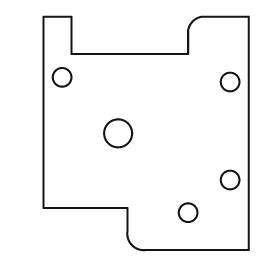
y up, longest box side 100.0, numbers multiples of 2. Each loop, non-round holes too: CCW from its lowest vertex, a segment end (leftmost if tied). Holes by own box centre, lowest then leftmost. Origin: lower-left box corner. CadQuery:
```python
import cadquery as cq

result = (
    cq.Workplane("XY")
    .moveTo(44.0, 0.0)
    .lineTo(88.0, 0.0)
    .lineTo(88.0, 100.0)
    .lineTo(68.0, 100.0)
    .threePointArc((64.0, 98.0), (62.0, 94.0))
    .lineTo(62.0, 84.0)
    .lineTo(12.0, 84.0)
    .lineTo(12.0, 100.0)
    .lineTo(0.0, 100.0)
    .lineTo(0.0, 18.0)
    .lineTo(36.0, 18.0)
    .lineTo(36.0, 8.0)
    .threePointArc((38.0, 2.0), (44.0, 0.0))
    .close()
    .moveTo(62.0, 16.0)
    .circle(4.0)
    .moveTo(80.0, 30.0)
    .circle(4.0)
    .moveTo(32.0, 50.0)
    .circle(6.0)
    .moveTo(80.0, 72.0)
    .circle(4.0)
    .moveTo(8.0, 74.0)
    .circle(4.0)
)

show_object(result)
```